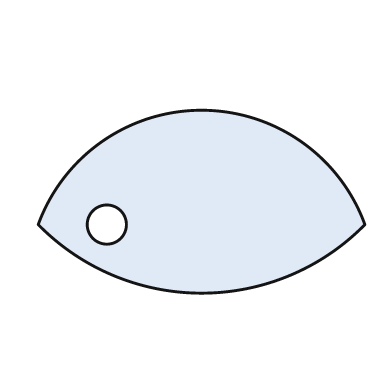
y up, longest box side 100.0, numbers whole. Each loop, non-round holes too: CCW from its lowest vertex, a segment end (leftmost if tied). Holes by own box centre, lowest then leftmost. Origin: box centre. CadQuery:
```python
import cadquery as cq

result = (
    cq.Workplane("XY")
    .moveTo(-50.0, -7.0)
    .threePointArc((0.0, -28.0), (50.0, -7.0))
    .threePointArc((0.0, 28.0), (-50.0, -7.0))
    .close()
    .moveTo(-29.0, -7.0)
    .circle(6.0)
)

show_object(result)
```